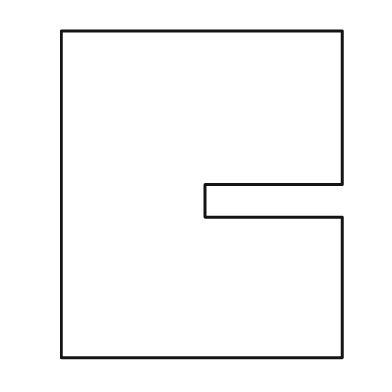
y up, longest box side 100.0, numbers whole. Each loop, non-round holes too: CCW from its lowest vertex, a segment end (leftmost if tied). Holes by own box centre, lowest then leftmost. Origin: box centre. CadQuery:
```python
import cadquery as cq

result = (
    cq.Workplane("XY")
    .moveTo(-43.0, -50.0)
    .lineTo(43.0, -50.0)
    .lineTo(43.0, -7.0)
    .lineTo(1.0, -7.0)
    .lineTo(1.0, 3.0)
    .lineTo(43.0, 3.0)
    .lineTo(43.0, 50.0)
    .lineTo(-43.0, 50.0)
    .close()
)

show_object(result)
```